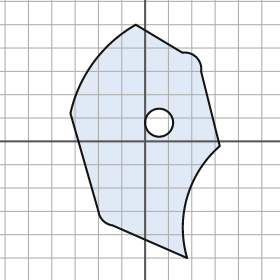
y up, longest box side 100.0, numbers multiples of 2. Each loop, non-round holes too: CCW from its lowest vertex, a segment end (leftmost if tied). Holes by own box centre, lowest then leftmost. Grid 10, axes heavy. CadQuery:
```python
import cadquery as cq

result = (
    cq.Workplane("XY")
    .moveTo(18.0, -50.0)
    .threePointArc((18.0, -24.0), (32.0, -2.0))
    .lineTo(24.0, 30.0)
    .threePointArc((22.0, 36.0), (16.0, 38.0))
    .lineTo(-4.0, 50.0)
    .threePointArc((-22.0, 34.0), (-32.0, 12.0))
    .lineTo(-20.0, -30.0)
    .threePointArc((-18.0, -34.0), (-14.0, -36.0))
    .close()
    .moveTo(6.0, 8.0)
    .circle(6.0)
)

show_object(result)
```